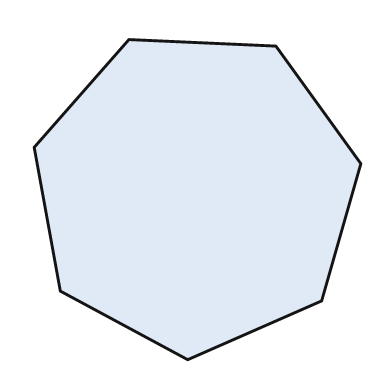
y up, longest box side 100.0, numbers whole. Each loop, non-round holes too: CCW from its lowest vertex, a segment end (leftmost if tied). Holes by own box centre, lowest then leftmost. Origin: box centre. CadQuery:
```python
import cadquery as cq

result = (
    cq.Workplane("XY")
    .moveTo(-3.0, -49.0)
    .lineTo(38.0, -31.0)
    .lineTo(50.0, 11.0)
    .lineTo(24.0, 47.0)
    .lineTo(-21.0, 49.0)
    .lineTo(-50.0, 16.0)
    .lineTo(-42.0, -28.0)
    .close()
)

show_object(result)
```